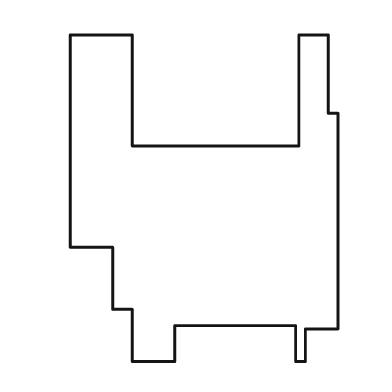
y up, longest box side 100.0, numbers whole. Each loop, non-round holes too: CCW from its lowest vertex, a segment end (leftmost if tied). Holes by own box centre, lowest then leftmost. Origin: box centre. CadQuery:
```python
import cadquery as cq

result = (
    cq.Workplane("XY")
    .moveTo(-22.0, -50.0)
    .lineTo(-9.0, -50.0)
    .lineTo(-9.0, -39.0)
    .lineTo(28.0, -39.0)
    .lineTo(28.0, -50.0)
    .lineTo(31.0, -50.0)
    .lineTo(31.0, -40.0)
    .lineTo(41.0, -40.0)
    .lineTo(41.0, 26.0)
    .lineTo(38.0, 26.0)
    .lineTo(38.0, 50.0)
    .lineTo(29.0, 50.0)
    .lineTo(29.0, 16.0)
    .lineTo(-22.0, 16.0)
    .lineTo(-22.0, 50.0)
    .lineTo(-41.0, 50.0)
    .lineTo(-41.0, -15.0)
    .lineTo(-28.0, -15.0)
    .lineTo(-28.0, -34.0)
    .lineTo(-22.0, -34.0)
    .close()
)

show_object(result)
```